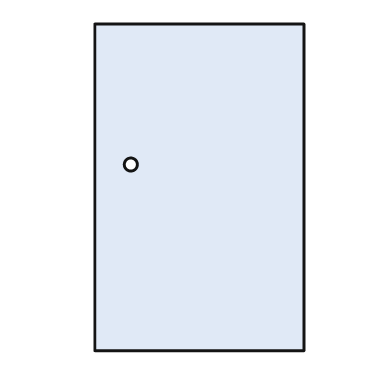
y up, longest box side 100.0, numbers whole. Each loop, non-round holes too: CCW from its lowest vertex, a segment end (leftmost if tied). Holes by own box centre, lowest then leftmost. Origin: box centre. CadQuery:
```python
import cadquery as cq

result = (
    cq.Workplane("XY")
    .moveTo(-32.0, -50.0)
    .lineTo(32.0, -50.0)
    .lineTo(32.0, 50.0)
    .lineTo(-32.0, 50.0)
    .close()
    .moveTo(-21.0, 7.0)
    .circle(2.0)
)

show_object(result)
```